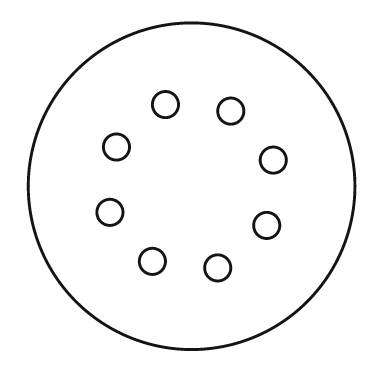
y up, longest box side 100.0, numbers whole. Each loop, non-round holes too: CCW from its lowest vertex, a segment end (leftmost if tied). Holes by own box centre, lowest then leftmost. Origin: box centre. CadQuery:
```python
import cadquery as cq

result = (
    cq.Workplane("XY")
    .moveTo(0.0, 0.0)
    .circle(50.0)
    .moveTo(8.0, -25.0)
    .circle(4.0)
    .moveTo(-12.0, -23.0)
    .circle(4.0)
    .moveTo(23.0, -12.0)
    .circle(4.0)
    .moveTo(-25.0, -8.0)
    .circle(4.0)
    .moveTo(25.0, 8.0)
    .circle(4.0)
    .moveTo(-23.0, 12.0)
    .circle(4.0)
    .moveTo(12.0, 23.0)
    .circle(4.0)
    .moveTo(-8.0, 25.0)
    .circle(4.0)
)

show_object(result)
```